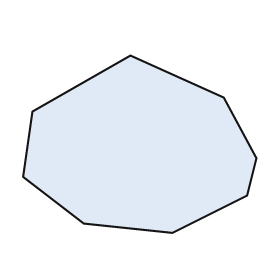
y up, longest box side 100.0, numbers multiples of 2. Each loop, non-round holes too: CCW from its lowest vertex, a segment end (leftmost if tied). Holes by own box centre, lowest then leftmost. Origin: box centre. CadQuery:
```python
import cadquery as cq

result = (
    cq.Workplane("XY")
    .moveTo(14.0, -38.0)
    .lineTo(46.0, -22.0)
    .lineTo(50.0, -6.0)
    .lineTo(36.0, 20.0)
    .lineTo(-4.0, 38.0)
    .lineTo(-46.0, 14.0)
    .lineTo(-50.0, -14.0)
    .lineTo(-24.0, -34.0)
    .close()
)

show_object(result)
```